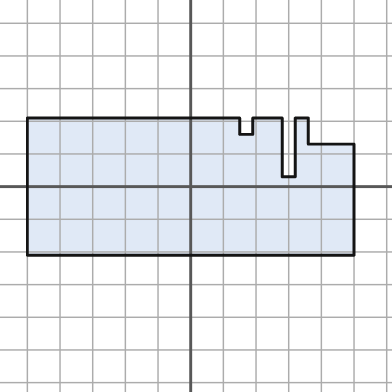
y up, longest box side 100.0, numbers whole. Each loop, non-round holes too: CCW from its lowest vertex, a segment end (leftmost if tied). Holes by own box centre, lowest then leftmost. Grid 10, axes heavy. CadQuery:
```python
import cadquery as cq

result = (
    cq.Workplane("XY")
    .moveTo(-50.0, -21.0)
    .lineTo(50.0, -21.0)
    .lineTo(50.0, 13.0)
    .lineTo(36.0, 13.0)
    .lineTo(36.0, 21.0)
    .lineTo(32.0, 21.0)
    .lineTo(32.0, 3.0)
    .lineTo(28.0, 3.0)
    .lineTo(28.0, 21.0)
    .lineTo(19.0, 21.0)
    .lineTo(19.0, 16.0)
    .lineTo(15.0, 16.0)
    .lineTo(15.0, 21.0)
    .lineTo(-50.0, 21.0)
    .close()
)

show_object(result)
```